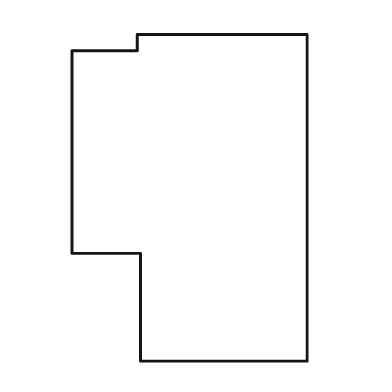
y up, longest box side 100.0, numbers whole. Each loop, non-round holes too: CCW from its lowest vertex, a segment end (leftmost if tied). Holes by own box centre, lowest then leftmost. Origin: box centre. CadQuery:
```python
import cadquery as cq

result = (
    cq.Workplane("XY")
    .moveTo(-15.0, -50.0)
    .lineTo(36.0, -50.0)
    .lineTo(36.0, 50.0)
    .lineTo(-16.0, 50.0)
    .lineTo(-16.0, 45.0)
    .lineTo(-36.0, 45.0)
    .lineTo(-36.0, -17.0)
    .lineTo(-15.0, -17.0)
    .close()
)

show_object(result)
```